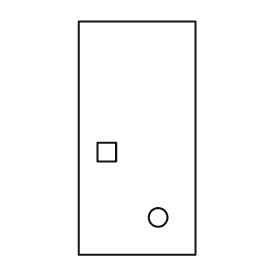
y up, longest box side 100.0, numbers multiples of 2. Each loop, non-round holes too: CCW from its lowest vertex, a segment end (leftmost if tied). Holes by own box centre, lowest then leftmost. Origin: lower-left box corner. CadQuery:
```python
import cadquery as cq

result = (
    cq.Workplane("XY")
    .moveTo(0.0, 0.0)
    .lineTo(50.0, 0.0)
    .lineTo(50.0, 100.0)
    .lineTo(0.0, 100.0)
    .close()
    .moveTo(34.0, 16.0)
    .circle(4.0)
    .moveTo(8.0, 40.0)
    .lineTo(16.0, 40.0)
    .lineTo(16.0, 48.0)
    .lineTo(8.0, 48.0)
    .close()
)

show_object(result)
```